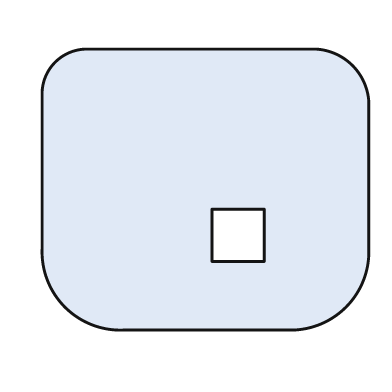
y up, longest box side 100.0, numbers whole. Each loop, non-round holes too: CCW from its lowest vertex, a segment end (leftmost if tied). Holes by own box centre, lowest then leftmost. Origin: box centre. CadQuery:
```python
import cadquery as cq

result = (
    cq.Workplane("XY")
    .moveTo(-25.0, -43.0)
    .lineTo(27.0, -43.0)
    .threePointArc((43.0, -36.0), (50.0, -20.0))
    .lineTo(50.0, 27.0)
    .threePointArc((45.0, 38.0), (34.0, 43.0))
    .lineTo(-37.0, 43.0)
    .threePointArc((-46.0, 39.0), (-50.0, 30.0))
    .lineTo(-50.0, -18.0)
    .threePointArc((-43.0, -36.0), (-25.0, -43.0))
    .close()
    .moveTo(2.0, -22.0)
    .lineTo(18.0, -22.0)
    .lineTo(18.0, -6.0)
    .lineTo(2.0, -6.0)
    .close()
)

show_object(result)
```